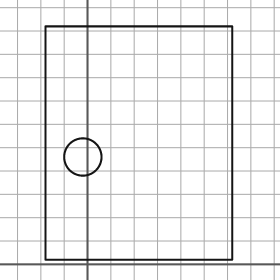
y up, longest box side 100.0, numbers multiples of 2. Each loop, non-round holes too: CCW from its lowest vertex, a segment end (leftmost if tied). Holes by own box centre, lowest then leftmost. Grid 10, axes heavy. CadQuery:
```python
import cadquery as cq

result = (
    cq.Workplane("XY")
    .moveTo(-18.0, 2.0)
    .lineTo(62.0, 2.0)
    .lineTo(62.0, 102.0)
    .lineTo(-18.0, 102.0)
    .close()
    .moveTo(-2.0, 46.0)
    .circle(8.0)
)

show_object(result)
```